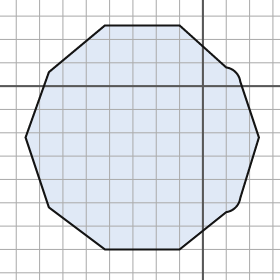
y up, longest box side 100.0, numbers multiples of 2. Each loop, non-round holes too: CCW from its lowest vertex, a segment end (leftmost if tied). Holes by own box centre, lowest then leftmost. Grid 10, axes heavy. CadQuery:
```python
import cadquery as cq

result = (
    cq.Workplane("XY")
    .moveTo(-42.0, -70.0)
    .lineTo(-10.0, -70.0)
    .lineTo(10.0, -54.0)
    .threePointArc((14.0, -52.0), (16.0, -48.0))
    .lineTo(24.0, -22.0)
    .lineTo(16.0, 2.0)
    .threePointArc((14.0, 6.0), (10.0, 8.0))
    .lineTo(-10.0, 26.0)
    .lineTo(-42.0, 26.0)
    .lineTo(-66.0, 6.0)
    .lineTo(-76.0, -22.0)
    .lineTo(-66.0, -52.0)
    .close()
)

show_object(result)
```